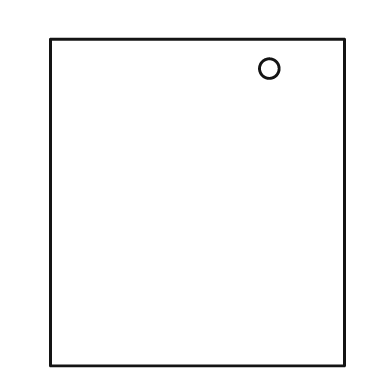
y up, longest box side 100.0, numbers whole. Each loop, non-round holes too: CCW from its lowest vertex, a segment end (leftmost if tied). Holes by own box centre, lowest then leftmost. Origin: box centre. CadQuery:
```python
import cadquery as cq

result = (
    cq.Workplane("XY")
    .moveTo(-45.0, -50.0)
    .lineTo(45.0, -50.0)
    .lineTo(45.0, 50.0)
    .lineTo(-45.0, 50.0)
    .close()
    .moveTo(22.0, 41.0)
    .circle(3.0)
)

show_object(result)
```